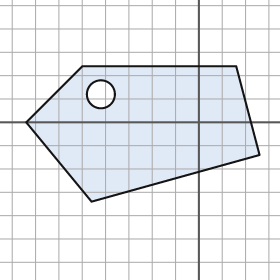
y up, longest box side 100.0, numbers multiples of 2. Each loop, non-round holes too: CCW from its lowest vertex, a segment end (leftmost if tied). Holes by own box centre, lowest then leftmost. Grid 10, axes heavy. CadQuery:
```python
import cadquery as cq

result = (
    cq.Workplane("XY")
    .moveTo(-46.0, -34.0)
    .lineTo(26.0, -14.0)
    .lineTo(16.0, 24.0)
    .lineTo(-50.0, 24.0)
    .lineTo(-74.0, 0.0)
    .close()
    .moveTo(-42.0, 12.0)
    .circle(6.0)
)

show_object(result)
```